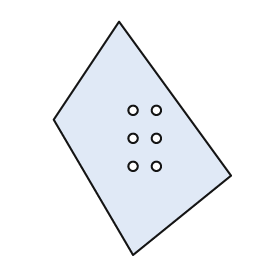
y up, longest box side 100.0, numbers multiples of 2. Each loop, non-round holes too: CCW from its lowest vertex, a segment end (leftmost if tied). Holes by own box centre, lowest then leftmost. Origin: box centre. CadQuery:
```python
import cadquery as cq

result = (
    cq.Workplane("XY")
    .moveTo(-4.0, -50.0)
    .lineTo(38.0, -16.0)
    .lineTo(-10.0, 50.0)
    .lineTo(-38.0, 8.0)
    .close()
    .moveTo(-4.0, -12.0)
    .circle(2.0)
    .moveTo(6.0, -12.0)
    .circle(2.0)
    .moveTo(-4.0, 0.0)
    .circle(2.0)
    .moveTo(6.0, 0.0)
    .circle(2.0)
    .moveTo(-4.0, 12.0)
    .circle(2.0)
    .moveTo(6.0, 12.0)
    .circle(2.0)
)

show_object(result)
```